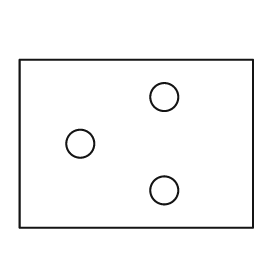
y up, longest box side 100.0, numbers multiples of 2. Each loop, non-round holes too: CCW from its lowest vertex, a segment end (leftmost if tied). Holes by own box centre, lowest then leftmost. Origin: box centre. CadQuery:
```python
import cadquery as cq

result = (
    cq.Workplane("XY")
    .moveTo(-50.0, -36.0)
    .lineTo(50.0, -36.0)
    .lineTo(50.0, 36.0)
    .lineTo(-50.0, 36.0)
    .close()
    .moveTo(12.0, -20.0)
    .circle(6.0)
    .moveTo(-24.0, 0.0)
    .circle(6.0)
    .moveTo(12.0, 20.0)
    .circle(6.0)
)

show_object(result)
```